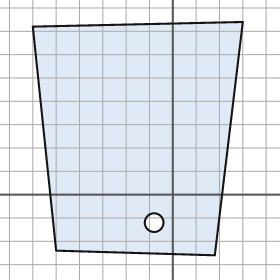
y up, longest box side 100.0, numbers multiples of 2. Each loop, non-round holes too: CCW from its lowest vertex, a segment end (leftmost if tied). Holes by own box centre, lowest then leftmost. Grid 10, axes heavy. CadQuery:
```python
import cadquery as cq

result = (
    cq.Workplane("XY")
    .moveTo(18.0, -26.0)
    .lineTo(30.0, 74.0)
    .lineTo(-60.0, 72.0)
    .lineTo(-50.0, -24.0)
    .close()
    .moveTo(-8.0, -12.0)
    .circle(4.0)
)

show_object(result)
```